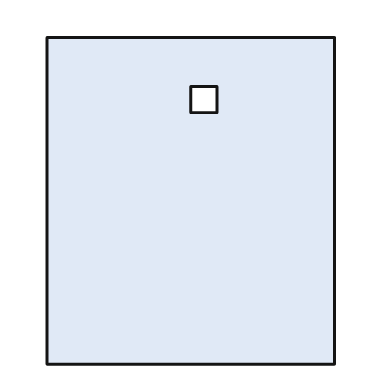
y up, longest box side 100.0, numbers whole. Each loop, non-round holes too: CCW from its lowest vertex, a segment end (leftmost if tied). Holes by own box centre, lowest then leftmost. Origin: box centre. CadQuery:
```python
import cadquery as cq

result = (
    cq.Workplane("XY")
    .moveTo(-44.0, -50.0)
    .lineTo(44.0, -50.0)
    .lineTo(44.0, 50.0)
    .lineTo(-44.0, 50.0)
    .close()
    .moveTo(0.0, 27.0)
    .lineTo(8.0, 27.0)
    .lineTo(8.0, 35.0)
    .lineTo(0.0, 35.0)
    .close()
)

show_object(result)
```